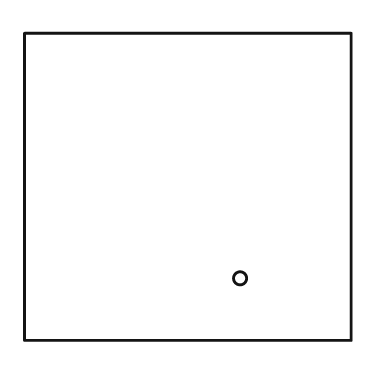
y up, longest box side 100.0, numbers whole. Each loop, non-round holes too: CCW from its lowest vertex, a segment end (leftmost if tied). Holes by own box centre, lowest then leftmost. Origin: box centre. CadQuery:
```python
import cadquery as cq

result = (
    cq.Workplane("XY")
    .moveTo(-50.0, -47.0)
    .lineTo(50.0, -47.0)
    .lineTo(50.0, 47.0)
    .lineTo(-50.0, 47.0)
    .close()
    .moveTo(16.0, -28.0)
    .circle(2.0)
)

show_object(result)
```